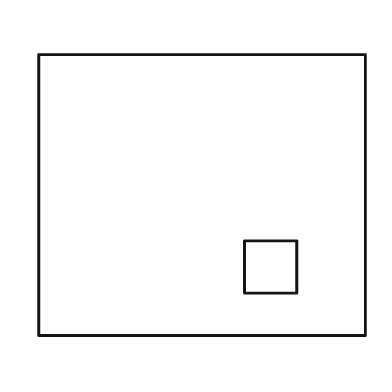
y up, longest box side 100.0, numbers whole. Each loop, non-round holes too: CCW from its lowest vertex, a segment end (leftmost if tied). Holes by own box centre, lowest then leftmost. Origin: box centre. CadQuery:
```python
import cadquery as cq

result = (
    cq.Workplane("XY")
    .moveTo(-50.0, -43.0)
    .lineTo(50.0, -43.0)
    .lineTo(50.0, 43.0)
    .lineTo(-50.0, 43.0)
    .close()
    .moveTo(13.0, -30.0)
    .lineTo(29.0, -30.0)
    .lineTo(29.0, -14.0)
    .lineTo(13.0, -14.0)
    .close()
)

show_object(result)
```